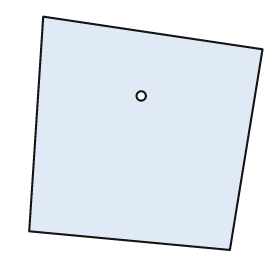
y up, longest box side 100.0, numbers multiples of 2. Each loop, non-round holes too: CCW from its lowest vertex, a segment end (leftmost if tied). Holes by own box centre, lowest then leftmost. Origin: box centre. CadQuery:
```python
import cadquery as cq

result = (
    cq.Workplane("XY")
    .moveTo(36.0, -50.0)
    .lineTo(50.0, 36.0)
    .lineTo(-44.0, 50.0)
    .lineTo(-50.0, -42.0)
    .close()
    .moveTo(-2.0, 16.0)
    .circle(2.0)
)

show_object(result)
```